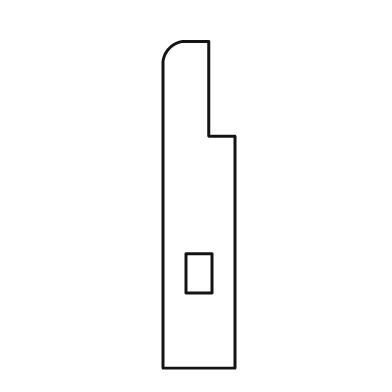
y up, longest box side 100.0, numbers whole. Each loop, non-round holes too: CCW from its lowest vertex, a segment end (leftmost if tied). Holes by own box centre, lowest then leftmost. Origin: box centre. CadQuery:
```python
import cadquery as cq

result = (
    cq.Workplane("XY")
    .moveTo(-11.0, -50.0)
    .lineTo(11.0, -50.0)
    .lineTo(11.0, 21.0)
    .lineTo(3.0, 21.0)
    .lineTo(3.0, 50.0)
    .lineTo(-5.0, 50.0)
    .threePointArc((-9.0, 48.0), (-11.0, 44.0))
    .close()
    .moveTo(-4.0, -27.0)
    .lineTo(4.0, -27.0)
    .lineTo(4.0, -15.0)
    .lineTo(-4.0, -15.0)
    .close()
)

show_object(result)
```